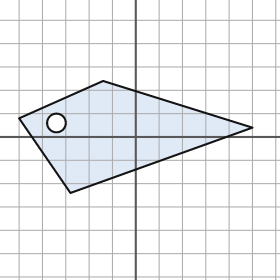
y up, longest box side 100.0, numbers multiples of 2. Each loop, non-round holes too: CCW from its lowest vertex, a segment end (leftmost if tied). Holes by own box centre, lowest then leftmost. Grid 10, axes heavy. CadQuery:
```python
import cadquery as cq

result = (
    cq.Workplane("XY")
    .moveTo(-28.0, -24.0)
    .lineTo(50.0, 4.0)
    .lineTo(-14.0, 24.0)
    .lineTo(-50.0, 8.0)
    .close()
    .moveTo(-34.0, 6.0)
    .circle(4.0)
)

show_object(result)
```